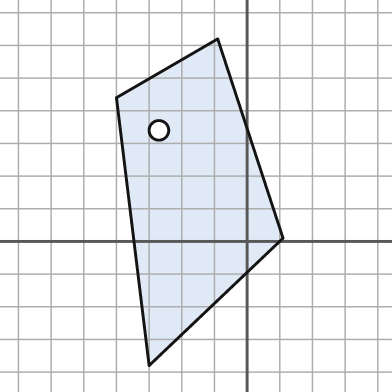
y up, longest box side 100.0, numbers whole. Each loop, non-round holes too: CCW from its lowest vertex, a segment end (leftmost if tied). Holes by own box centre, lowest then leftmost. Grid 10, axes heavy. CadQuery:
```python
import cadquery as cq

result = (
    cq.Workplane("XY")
    .moveTo(-30.0, -38.0)
    .lineTo(11.0, 1.0)
    .lineTo(-9.0, 62.0)
    .lineTo(-40.0, 44.0)
    .close()
    .moveTo(-27.0, 34.0)
    .circle(3.0)
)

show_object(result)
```